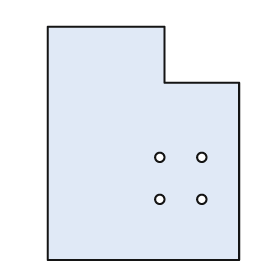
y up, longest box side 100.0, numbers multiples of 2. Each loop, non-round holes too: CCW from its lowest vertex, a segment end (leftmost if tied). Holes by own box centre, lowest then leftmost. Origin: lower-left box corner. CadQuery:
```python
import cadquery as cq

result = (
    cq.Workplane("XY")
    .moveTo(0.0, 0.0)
    .lineTo(82.0, 0.0)
    .lineTo(82.0, 76.0)
    .lineTo(50.0, 76.0)
    .lineTo(50.0, 100.0)
    .lineTo(0.0, 100.0)
    .close()
    .moveTo(48.0, 26.0)
    .circle(2.0)
    .moveTo(66.0, 26.0)
    .circle(2.0)
    .moveTo(48.0, 44.0)
    .circle(2.0)
    .moveTo(66.0, 44.0)
    .circle(2.0)
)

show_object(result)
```